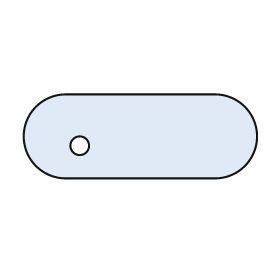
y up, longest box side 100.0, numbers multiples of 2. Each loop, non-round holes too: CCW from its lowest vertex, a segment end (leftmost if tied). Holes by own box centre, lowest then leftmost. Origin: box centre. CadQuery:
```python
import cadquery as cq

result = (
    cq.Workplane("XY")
    .moveTo(-32.0, -18.0)
    .lineTo(32.0, -18.0)
    .threePointArc((50.0, 0.0), (32.0, 18.0))
    .lineTo(-32.0, 18.0)
    .threePointArc((-50.0, 0.0), (-32.0, -18.0))
    .close()
    .moveTo(-26.0, -4.0)
    .circle(4.0)
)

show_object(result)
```